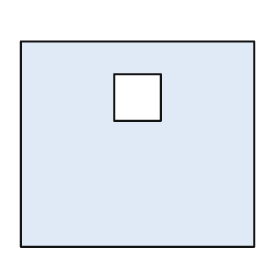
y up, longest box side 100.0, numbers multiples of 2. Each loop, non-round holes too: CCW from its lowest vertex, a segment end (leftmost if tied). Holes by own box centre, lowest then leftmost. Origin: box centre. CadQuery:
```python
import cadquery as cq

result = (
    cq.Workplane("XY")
    .moveTo(-50.0, -44.0)
    .lineTo(50.0, -44.0)
    .lineTo(50.0, 44.0)
    .lineTo(-50.0, 44.0)
    .close()
    .moveTo(-10.0, 10.0)
    .lineTo(10.0, 10.0)
    .lineTo(10.0, 30.0)
    .lineTo(-10.0, 30.0)
    .close()
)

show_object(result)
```